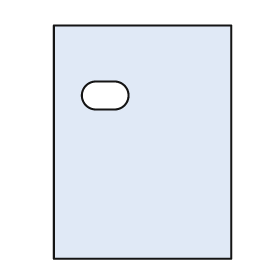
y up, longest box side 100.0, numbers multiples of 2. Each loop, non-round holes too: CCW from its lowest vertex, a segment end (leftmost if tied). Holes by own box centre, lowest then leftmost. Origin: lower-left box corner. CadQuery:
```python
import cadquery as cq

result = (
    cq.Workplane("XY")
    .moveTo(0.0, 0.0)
    .lineTo(76.0, 0.0)
    .lineTo(76.0, 100.0)
    .lineTo(0.0, 100.0)
    .close()
    .moveTo(18.0, 64.0)
    .lineTo(26.0, 64.0)
    .threePointArc((32.0, 70.0), (26.0, 76.0))
    .lineTo(18.0, 76.0)
    .threePointArc((12.0, 70.0), (18.0, 64.0))
    .close()
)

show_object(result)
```